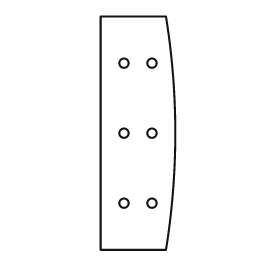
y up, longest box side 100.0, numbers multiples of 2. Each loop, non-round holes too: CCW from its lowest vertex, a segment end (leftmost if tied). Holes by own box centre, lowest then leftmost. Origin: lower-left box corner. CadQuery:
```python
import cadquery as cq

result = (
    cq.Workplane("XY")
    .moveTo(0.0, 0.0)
    .lineTo(28.0, 0.0)
    .threePointArc((32.0, 50.0), (28.0, 100.0))
    .lineTo(0.0, 100.0)
    .close()
    .moveTo(10.0, 20.0)
    .circle(2.0)
    .moveTo(22.0, 20.0)
    .circle(2.0)
    .moveTo(10.0, 50.0)
    .circle(2.0)
    .moveTo(22.0, 50.0)
    .circle(2.0)
    .moveTo(10.0, 80.0)
    .circle(2.0)
    .moveTo(22.0, 80.0)
    .circle(2.0)
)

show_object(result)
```